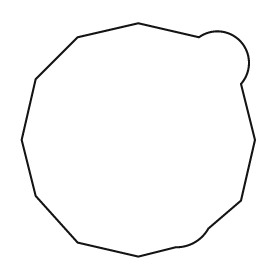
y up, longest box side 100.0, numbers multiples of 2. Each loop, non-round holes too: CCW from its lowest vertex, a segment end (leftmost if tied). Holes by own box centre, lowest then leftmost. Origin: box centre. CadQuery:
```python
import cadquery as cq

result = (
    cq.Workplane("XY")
    .moveTo(0.0, -50.0)
    .lineTo(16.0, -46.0)
    .threePointArc((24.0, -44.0), (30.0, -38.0))
    .lineTo(44.0, -26.0)
    .lineTo(50.0, 0.0)
    .lineTo(44.0, 24.0)
    .threePointArc((44.0, 42.0), (26.0, 44.0))
    .lineTo(0.0, 50.0)
    .lineTo(-26.0, 44.0)
    .lineTo(-44.0, 26.0)
    .lineTo(-50.0, 0.0)
    .lineTo(-44.0, -24.0)
    .lineTo(-26.0, -44.0)
    .close()
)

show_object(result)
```